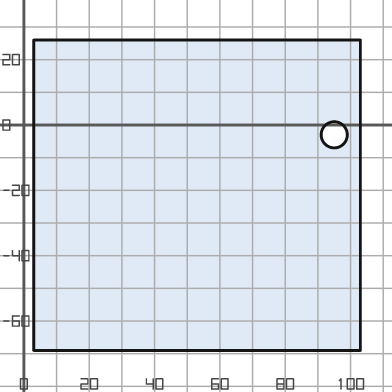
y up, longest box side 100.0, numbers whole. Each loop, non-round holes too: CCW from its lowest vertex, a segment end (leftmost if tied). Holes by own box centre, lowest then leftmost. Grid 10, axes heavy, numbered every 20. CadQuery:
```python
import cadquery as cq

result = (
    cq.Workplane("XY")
    .moveTo(3.0, -69.0)
    .lineTo(103.0, -69.0)
    .lineTo(103.0, 26.0)
    .lineTo(3.0, 26.0)
    .close()
    .moveTo(95.0, -3.0)
    .circle(4.0)
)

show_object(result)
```